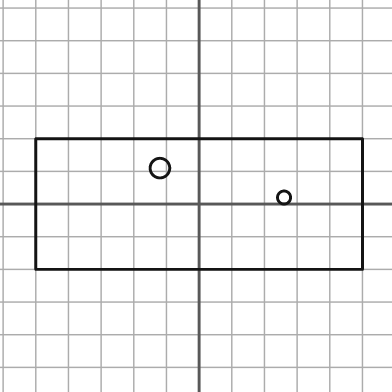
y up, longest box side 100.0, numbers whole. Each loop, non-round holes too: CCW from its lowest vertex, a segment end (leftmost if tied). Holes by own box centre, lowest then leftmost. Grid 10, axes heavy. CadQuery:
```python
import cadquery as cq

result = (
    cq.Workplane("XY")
    .moveTo(-50.0, -20.0)
    .lineTo(50.0, -20.0)
    .lineTo(50.0, 20.0)
    .lineTo(-50.0, 20.0)
    .close()
    .moveTo(26.0, 2.0)
    .circle(2.0)
    .moveTo(-12.0, 11.0)
    .circle(3.0)
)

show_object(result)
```